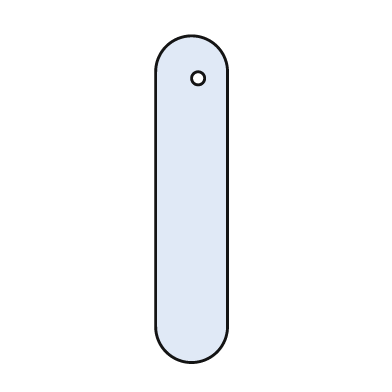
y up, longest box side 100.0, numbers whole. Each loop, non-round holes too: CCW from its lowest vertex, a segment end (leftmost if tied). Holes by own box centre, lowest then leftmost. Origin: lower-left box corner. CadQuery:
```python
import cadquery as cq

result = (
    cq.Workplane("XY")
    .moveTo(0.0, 11.0)
    .threePointArc((11.0, 0.0), (22.0, 11.0))
    .lineTo(22.0, 89.0)
    .threePointArc((11.0, 100.0), (0.0, 89.0))
    .close()
    .moveTo(13.0, 87.0)
    .circle(2.0)
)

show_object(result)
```